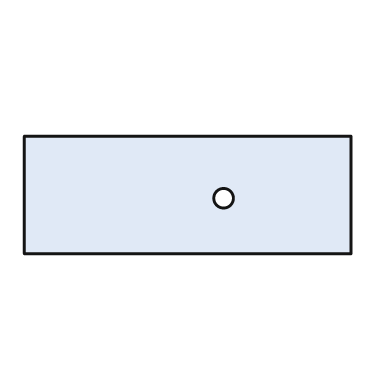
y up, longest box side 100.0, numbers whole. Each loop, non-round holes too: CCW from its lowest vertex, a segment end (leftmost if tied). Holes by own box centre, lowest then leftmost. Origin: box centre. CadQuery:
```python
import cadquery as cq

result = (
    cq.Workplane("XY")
    .moveTo(-50.0, -18.0)
    .lineTo(50.0, -18.0)
    .lineTo(50.0, 18.0)
    .lineTo(-50.0, 18.0)
    .close()
    .moveTo(11.0, -1.0)
    .circle(3.0)
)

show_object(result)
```